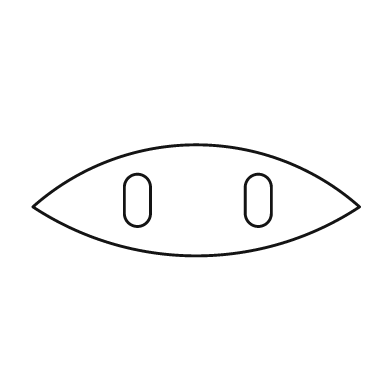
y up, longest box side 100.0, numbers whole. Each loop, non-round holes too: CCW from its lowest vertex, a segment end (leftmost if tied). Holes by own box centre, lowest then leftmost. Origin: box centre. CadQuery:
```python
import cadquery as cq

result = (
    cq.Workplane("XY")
    .moveTo(-50.0, -2.0)
    .threePointArc((0.0, -17.0), (50.0, -2.0))
    .threePointArc((0.0, 17.0), (-50.0, -2.0))
    .close()
    .moveTo(-22.0, -4.0)
    .threePointArc((-18.0, -8.0), (-14.0, -4.0))
    .lineTo(-14.0, 4.0)
    .threePointArc((-18.0, 8.0), (-22.0, 4.0))
    .close()
    .moveTo(15.0, -4.0)
    .threePointArc((19.0, -8.0), (23.0, -4.0))
    .lineTo(23.0, 4.0)
    .threePointArc((19.0, 8.0), (15.0, 4.0))
    .close()
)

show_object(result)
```